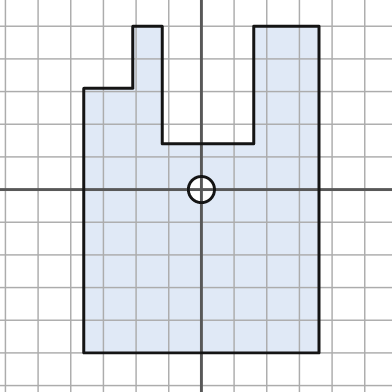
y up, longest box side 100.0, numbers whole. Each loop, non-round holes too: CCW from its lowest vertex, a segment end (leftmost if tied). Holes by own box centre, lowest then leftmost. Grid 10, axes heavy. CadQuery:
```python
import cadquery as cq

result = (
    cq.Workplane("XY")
    .moveTo(-36.0, -50.0)
    .lineTo(36.0, -50.0)
    .lineTo(36.0, 50.0)
    .lineTo(16.0, 50.0)
    .lineTo(16.0, 14.0)
    .lineTo(-12.0, 14.0)
    .lineTo(-12.0, 50.0)
    .lineTo(-21.0, 50.0)
    .lineTo(-21.0, 31.0)
    .lineTo(-36.0, 31.0)
    .close()
    .moveTo(0.0, 0.0)
    .circle(4.0)
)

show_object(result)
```